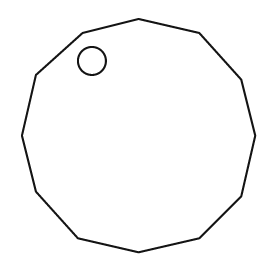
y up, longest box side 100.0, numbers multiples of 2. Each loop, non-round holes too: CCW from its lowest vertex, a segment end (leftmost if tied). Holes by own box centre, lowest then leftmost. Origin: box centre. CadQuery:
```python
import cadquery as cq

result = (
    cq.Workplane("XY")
    .moveTo(0.0, -50.0)
    .lineTo(26.0, -44.0)
    .lineTo(44.0, -26.0)
    .lineTo(50.0, 0.0)
    .lineTo(44.0, 24.0)
    .lineTo(26.0, 44.0)
    .lineTo(0.0, 50.0)
    .lineTo(-24.0, 44.0)
    .lineTo(-44.0, 26.0)
    .lineTo(-50.0, 0.0)
    .lineTo(-44.0, -24.0)
    .lineTo(-26.0, -44.0)
    .close()
    .moveTo(-20.0, 32.0)
    .circle(6.0)
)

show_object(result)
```